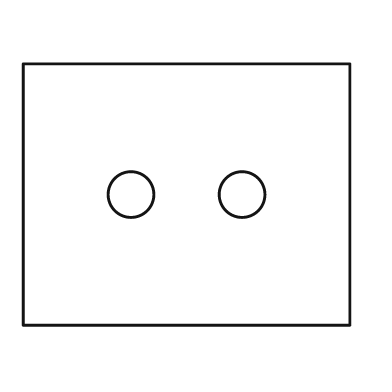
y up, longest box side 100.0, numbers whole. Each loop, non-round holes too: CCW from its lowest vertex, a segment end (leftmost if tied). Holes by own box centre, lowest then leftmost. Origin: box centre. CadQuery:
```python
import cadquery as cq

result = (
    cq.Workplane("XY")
    .moveTo(-50.0, -40.0)
    .lineTo(50.0, -40.0)
    .lineTo(50.0, 40.0)
    .lineTo(-50.0, 40.0)
    .close()
    .moveTo(-17.0, 0.0)
    .circle(7.0)
    .moveTo(17.0, 0.0)
    .circle(7.0)
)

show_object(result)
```